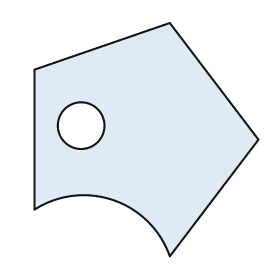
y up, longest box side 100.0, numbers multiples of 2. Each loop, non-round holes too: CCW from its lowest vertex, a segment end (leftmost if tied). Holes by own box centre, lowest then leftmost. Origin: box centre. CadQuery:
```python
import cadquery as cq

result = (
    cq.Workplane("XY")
    .moveTo(10.0, -50.0)
    .lineTo(48.0, 0.0)
    .lineTo(10.0, 50.0)
    .lineTo(-48.0, 30.0)
    .lineTo(-48.0, -30.0)
    .threePointArc((-14.0, -26.0), (10.0, -50.0))
    .close()
    .moveTo(-28.0, 6.0)
    .circle(10.0)
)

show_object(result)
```